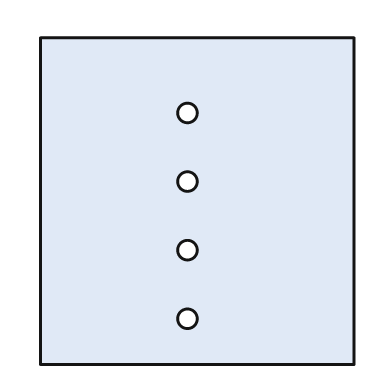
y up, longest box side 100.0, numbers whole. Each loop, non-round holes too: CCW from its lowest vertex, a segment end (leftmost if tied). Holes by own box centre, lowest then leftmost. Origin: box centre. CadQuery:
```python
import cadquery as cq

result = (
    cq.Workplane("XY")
    .moveTo(-48.0, -50.0)
    .lineTo(48.0, -50.0)
    .lineTo(48.0, 50.0)
    .lineTo(-48.0, 50.0)
    .close()
    .moveTo(-3.0, -36.0)
    .circle(3.0)
    .moveTo(-3.0, -15.0)
    .circle(3.0)
    .moveTo(-3.0, 6.0)
    .circle(3.0)
    .moveTo(-3.0, 27.0)
    .circle(3.0)
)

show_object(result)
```